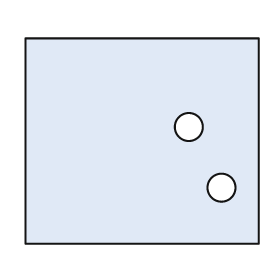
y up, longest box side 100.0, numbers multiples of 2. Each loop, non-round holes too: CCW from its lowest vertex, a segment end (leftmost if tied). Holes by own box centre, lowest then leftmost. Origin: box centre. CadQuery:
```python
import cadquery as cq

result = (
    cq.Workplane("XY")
    .moveTo(-50.0, -44.0)
    .lineTo(50.0, -44.0)
    .lineTo(50.0, 44.0)
    .lineTo(-50.0, 44.0)
    .close()
    .moveTo(34.0, -20.0)
    .circle(6.0)
    .moveTo(20.0, 6.0)
    .circle(6.0)
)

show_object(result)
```